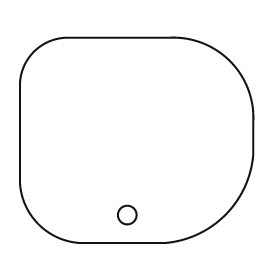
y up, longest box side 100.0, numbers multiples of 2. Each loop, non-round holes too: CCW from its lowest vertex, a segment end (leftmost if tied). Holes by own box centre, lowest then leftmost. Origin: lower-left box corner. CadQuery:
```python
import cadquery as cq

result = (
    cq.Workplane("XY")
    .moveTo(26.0, 0.0)
    .lineTo(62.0, 0.0)
    .threePointArc((88.0, 12.0), (100.0, 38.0))
    .lineTo(100.0, 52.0)
    .threePointArc((90.0, 78.0), (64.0, 88.0))
    .lineTo(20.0, 88.0)
    .threePointArc((6.0, 82.0), (0.0, 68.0))
    .lineTo(0.0, 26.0)
    .threePointArc((8.0, 8.0), (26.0, 0.0))
    .close()
    .moveTo(46.0, 12.0)
    .circle(4.0)
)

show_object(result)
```